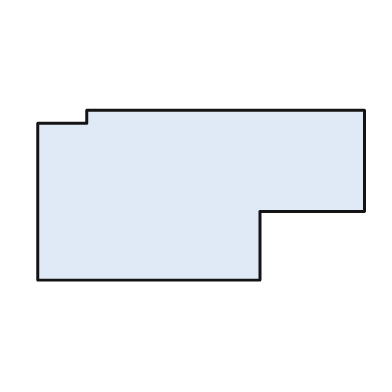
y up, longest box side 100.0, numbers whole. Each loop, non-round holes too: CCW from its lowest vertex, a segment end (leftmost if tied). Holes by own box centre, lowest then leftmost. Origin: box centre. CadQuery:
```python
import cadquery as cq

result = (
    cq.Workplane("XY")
    .moveTo(-50.0, -26.0)
    .lineTo(18.0, -26.0)
    .lineTo(18.0, -5.0)
    .lineTo(50.0, -5.0)
    .lineTo(50.0, 26.0)
    .lineTo(-35.0, 26.0)
    .lineTo(-35.0, 22.0)
    .lineTo(-50.0, 22.0)
    .close()
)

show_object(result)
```